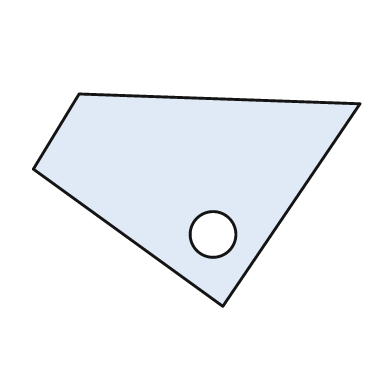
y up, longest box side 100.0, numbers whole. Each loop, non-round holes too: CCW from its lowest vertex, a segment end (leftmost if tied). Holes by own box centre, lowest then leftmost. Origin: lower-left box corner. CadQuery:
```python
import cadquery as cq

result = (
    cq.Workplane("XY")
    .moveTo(58.0, 0.0)
    .lineTo(100.0, 62.0)
    .lineTo(14.0, 65.0)
    .lineTo(0.0, 42.0)
    .close()
    .moveTo(55.0, 22.0)
    .circle(7.0)
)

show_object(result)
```